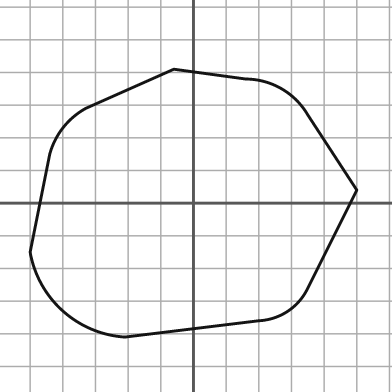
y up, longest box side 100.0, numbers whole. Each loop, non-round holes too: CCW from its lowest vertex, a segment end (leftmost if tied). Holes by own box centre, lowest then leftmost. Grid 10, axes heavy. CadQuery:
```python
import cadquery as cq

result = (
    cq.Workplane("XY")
    .moveTo(-21.0, -41.0)
    .lineTo(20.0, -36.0)
    .threePointArc((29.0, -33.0), (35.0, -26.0))
    .lineTo(50.0, 4.0)
    .lineTo(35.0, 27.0)
    .threePointArc((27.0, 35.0), (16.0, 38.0))
    .lineTo(-6.0, 41.0)
    .lineTo(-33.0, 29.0)
    .threePointArc((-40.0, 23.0), (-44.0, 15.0))
    .lineTo(-50.0, -15.0)
    .threePointArc((-40.0, -33.0), (-21.0, -41.0))
    .close()
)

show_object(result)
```